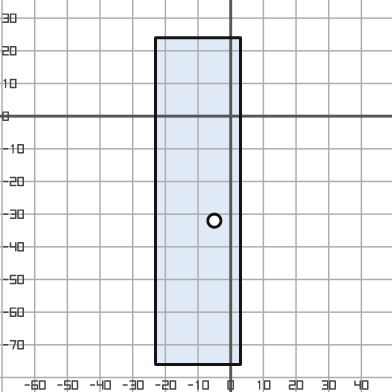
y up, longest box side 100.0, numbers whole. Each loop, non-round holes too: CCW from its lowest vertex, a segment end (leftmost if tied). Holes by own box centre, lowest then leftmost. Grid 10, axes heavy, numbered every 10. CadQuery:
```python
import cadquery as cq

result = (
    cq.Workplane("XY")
    .moveTo(-23.0, -76.0)
    .lineTo(3.0, -76.0)
    .lineTo(3.0, 24.0)
    .lineTo(-23.0, 24.0)
    .close()
    .moveTo(-5.0, -32.0)
    .circle(2.0)
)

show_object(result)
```